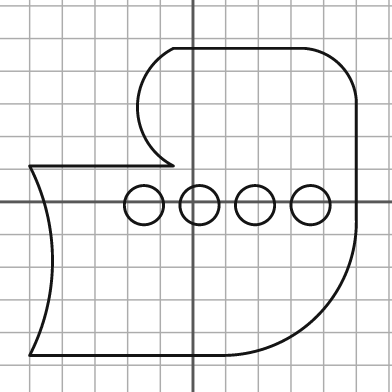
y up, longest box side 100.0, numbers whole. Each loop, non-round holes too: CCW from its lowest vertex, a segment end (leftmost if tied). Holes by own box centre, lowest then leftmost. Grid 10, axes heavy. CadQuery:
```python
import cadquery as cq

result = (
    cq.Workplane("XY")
    .moveTo(-50.0, -47.0)
    .lineTo(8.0, -47.0)
    .threePointArc((38.0, -35.0), (50.0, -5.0))
    .lineTo(50.0, 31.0)
    .threePointArc((45.0, 42.0), (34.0, 47.0))
    .lineTo(-6.0, 47.0)
    .threePointArc((-17.0, 29.0), (-6.0, 11.0))
    .lineTo(-50.0, 11.0)
    .threePointArc((-43.0, -18.0), (-50.0, -47.0))
    .close()
    .moveTo(-15.0, -1.0)
    .circle(6.0)
    .moveTo(2.0, -1.0)
    .circle(6.0)
    .moveTo(19.0, -1.0)
    .circle(6.0)
    .moveTo(36.0, -1.0)
    .circle(6.0)
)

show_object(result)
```